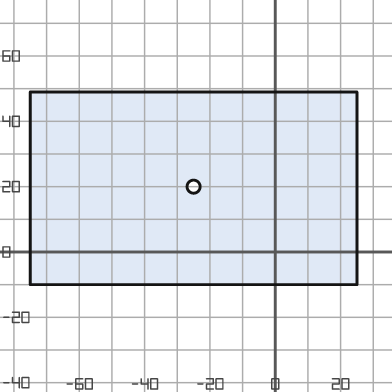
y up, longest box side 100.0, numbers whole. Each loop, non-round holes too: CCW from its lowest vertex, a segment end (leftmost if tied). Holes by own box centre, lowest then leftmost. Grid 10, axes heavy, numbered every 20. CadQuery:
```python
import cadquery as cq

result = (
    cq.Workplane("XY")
    .moveTo(-75.0, -10.0)
    .lineTo(25.0, -10.0)
    .lineTo(25.0, 49.0)
    .lineTo(-75.0, 49.0)
    .close()
    .moveTo(-25.0, 20.0)
    .circle(2.0)
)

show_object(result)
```